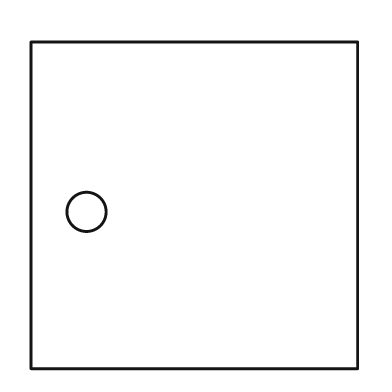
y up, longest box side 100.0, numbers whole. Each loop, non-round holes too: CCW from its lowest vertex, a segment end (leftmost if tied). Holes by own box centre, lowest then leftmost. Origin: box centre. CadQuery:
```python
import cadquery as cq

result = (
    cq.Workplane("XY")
    .moveTo(-50.0, -50.0)
    .lineTo(50.0, -50.0)
    .lineTo(50.0, 50.0)
    .lineTo(-50.0, 50.0)
    .close()
    .moveTo(-33.0, -2.0)
    .circle(6.0)
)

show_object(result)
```